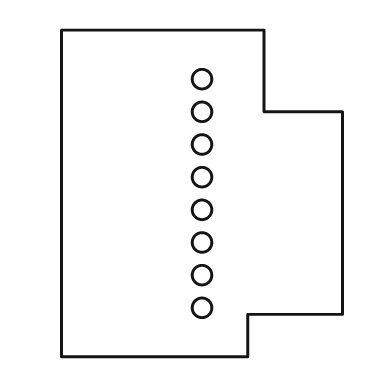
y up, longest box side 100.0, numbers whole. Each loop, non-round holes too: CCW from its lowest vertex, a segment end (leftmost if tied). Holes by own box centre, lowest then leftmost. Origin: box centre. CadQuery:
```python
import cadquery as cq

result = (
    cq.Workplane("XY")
    .moveTo(-43.0, -50.0)
    .lineTo(14.0, -50.0)
    .lineTo(14.0, -37.0)
    .lineTo(43.0, -37.0)
    .lineTo(43.0, 25.0)
    .lineTo(19.0, 25.0)
    .lineTo(19.0, 50.0)
    .lineTo(-43.0, 50.0)
    .close()
    .moveTo(0.0, -35.0)
    .circle(3.0)
    .moveTo(0.0, -25.0)
    .circle(3.0)
    .moveTo(0.0, -15.0)
    .circle(3.0)
    .moveTo(0.0, -5.0)
    .circle(3.0)
    .moveTo(0.0, 5.0)
    .circle(3.0)
    .moveTo(0.0, 15.0)
    .circle(3.0)
    .moveTo(0.0, 25.0)
    .circle(3.0)
    .moveTo(0.0, 35.0)
    .circle(3.0)
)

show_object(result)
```